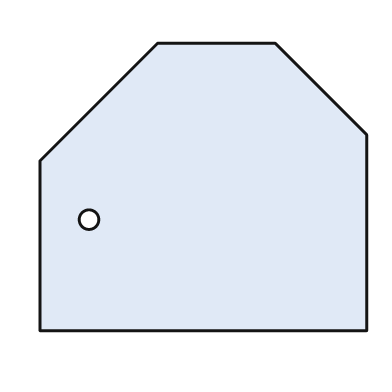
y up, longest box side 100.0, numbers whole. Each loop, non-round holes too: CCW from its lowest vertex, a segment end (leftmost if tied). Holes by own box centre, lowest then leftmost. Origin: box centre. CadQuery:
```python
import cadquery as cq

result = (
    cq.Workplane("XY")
    .moveTo(-50.0, -44.0)
    .lineTo(50.0, -44.0)
    .lineTo(50.0, 16.0)
    .lineTo(22.0, 44.0)
    .lineTo(-14.0, 44.0)
    .lineTo(-50.0, 8.0)
    .close()
    .moveTo(-35.0, -10.0)
    .circle(3.0)
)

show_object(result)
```